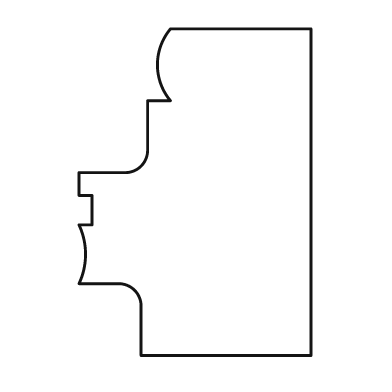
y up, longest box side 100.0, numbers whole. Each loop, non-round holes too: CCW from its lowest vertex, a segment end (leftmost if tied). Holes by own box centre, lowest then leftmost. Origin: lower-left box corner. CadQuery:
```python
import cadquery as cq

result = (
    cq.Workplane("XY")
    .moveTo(19.0, 0.0)
    .lineTo(71.0, 0.0)
    .lineTo(71.0, 100.0)
    .lineTo(28.0, 100.0)
    .threePointArc((24.0, 89.0), (28.0, 78.0))
    .lineTo(21.0, 78.0)
    .lineTo(21.0, 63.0)
    .threePointArc((19.0, 58.0), (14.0, 56.0))
    .lineTo(0.0, 56.0)
    .lineTo(0.0, 49.0)
    .lineTo(4.0, 49.0)
    .lineTo(4.0, 40.0)
    .lineTo(0.0, 40.0)
    .threePointArc((2.0, 31.0), (0.0, 22.0))
    .lineTo(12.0, 22.0)
    .threePointArc((17.0, 20.0), (19.0, 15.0))
    .close()
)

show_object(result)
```